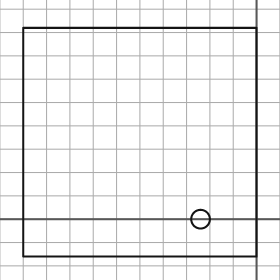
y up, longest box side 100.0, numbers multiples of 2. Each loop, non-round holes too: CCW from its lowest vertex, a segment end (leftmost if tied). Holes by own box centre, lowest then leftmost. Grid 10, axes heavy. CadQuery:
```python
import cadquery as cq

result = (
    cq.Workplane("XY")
    .moveTo(-100.0, -16.0)
    .lineTo(0.0, -16.0)
    .lineTo(0.0, 82.0)
    .lineTo(-100.0, 82.0)
    .close()
    .moveTo(-24.0, 0.0)
    .circle(4.0)
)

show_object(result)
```